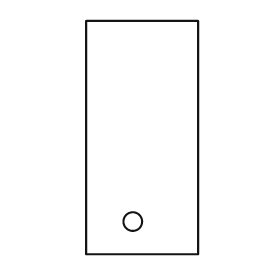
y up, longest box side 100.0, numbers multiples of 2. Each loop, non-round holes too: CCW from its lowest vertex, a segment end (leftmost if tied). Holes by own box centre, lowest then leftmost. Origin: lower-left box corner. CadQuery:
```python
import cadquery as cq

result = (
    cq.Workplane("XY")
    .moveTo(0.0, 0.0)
    .lineTo(48.0, 0.0)
    .lineTo(48.0, 100.0)
    .lineTo(0.0, 100.0)
    .close()
    .moveTo(20.0, 14.0)
    .circle(4.0)
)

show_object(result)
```